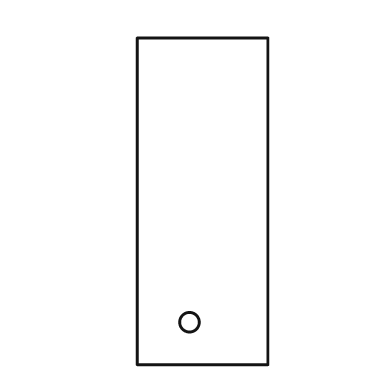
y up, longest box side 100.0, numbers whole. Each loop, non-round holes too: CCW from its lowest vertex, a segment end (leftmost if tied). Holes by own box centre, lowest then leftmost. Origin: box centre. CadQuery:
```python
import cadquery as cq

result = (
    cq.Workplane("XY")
    .moveTo(-20.0, -50.0)
    .lineTo(20.0, -50.0)
    .lineTo(20.0, 50.0)
    .lineTo(-20.0, 50.0)
    .close()
    .moveTo(-4.0, -37.0)
    .circle(3.0)
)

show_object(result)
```